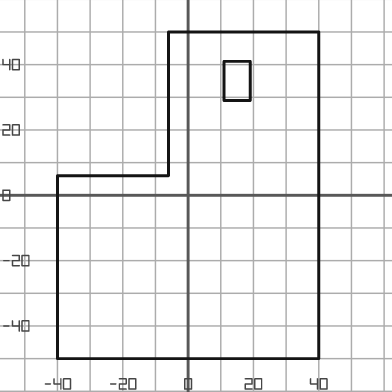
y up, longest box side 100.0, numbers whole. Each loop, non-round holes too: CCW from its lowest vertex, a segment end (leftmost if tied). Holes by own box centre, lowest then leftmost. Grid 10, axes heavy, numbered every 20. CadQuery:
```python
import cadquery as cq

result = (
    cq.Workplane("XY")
    .moveTo(-40.0, -50.0)
    .lineTo(40.0, -50.0)
    .lineTo(40.0, 50.0)
    .lineTo(-6.0, 50.0)
    .lineTo(-6.0, 6.0)
    .lineTo(-40.0, 6.0)
    .close()
    .moveTo(11.0, 29.0)
    .lineTo(19.0, 29.0)
    .lineTo(19.0, 41.0)
    .lineTo(11.0, 41.0)
    .close()
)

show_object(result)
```